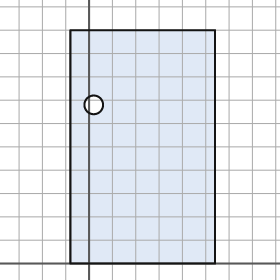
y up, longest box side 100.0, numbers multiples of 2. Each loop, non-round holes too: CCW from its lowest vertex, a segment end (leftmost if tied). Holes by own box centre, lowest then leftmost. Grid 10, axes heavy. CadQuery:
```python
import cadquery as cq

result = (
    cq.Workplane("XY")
    .moveTo(-8.0, 0.0)
    .lineTo(54.0, 0.0)
    .lineTo(54.0, 100.0)
    .lineTo(-8.0, 100.0)
    .close()
    .moveTo(2.0, 68.0)
    .circle(4.0)
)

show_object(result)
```